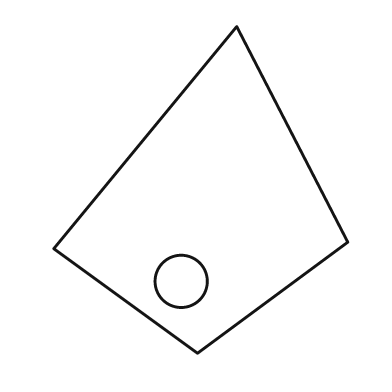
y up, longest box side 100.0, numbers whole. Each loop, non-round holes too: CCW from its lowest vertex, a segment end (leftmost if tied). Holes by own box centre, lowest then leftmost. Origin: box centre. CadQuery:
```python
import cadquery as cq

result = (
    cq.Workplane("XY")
    .moveTo(-1.0, -50.0)
    .lineTo(45.0, -16.0)
    .lineTo(11.0, 50.0)
    .lineTo(-45.0, -18.0)
    .close()
    .moveTo(-6.0, -28.0)
    .circle(8.0)
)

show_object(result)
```